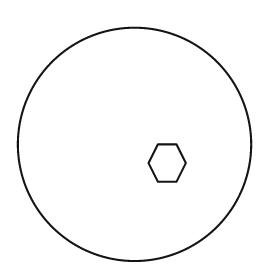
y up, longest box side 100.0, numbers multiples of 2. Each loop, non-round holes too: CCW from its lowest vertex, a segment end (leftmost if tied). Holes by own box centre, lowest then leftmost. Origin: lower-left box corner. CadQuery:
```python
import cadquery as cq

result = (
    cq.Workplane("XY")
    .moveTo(50.0, 50.0)
    .circle(50.0)
    .moveTo(60.0, 34.0)
    .lineTo(68.0, 34.0)
    .lineTo(72.0, 42.0)
    .lineTo(68.0, 50.0)
    .lineTo(60.0, 50.0)
    .lineTo(56.0, 42.0)
    .close()
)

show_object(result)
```